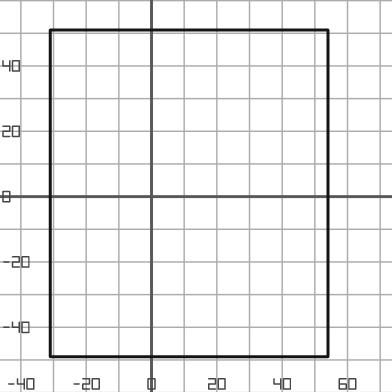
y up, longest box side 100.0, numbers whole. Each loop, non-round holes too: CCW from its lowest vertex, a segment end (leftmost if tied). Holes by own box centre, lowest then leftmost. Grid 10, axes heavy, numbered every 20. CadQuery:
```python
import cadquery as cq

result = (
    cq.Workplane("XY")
    .moveTo(-31.0, -49.0)
    .lineTo(54.0, -49.0)
    .lineTo(54.0, 51.0)
    .lineTo(-31.0, 51.0)
    .close()
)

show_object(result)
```